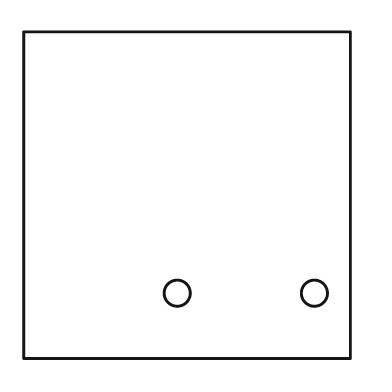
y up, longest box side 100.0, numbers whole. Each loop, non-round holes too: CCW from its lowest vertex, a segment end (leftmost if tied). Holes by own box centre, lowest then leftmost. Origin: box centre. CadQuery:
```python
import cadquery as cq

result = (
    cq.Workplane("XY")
    .moveTo(-50.0, -50.0)
    .lineTo(50.0, -50.0)
    .lineTo(50.0, 50.0)
    .lineTo(-50.0, 50.0)
    .close()
    .moveTo(-3.0, -30.0)
    .circle(4.0)
    .moveTo(39.0, -30.0)
    .circle(4.0)
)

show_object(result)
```